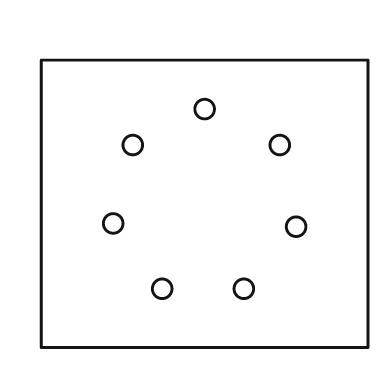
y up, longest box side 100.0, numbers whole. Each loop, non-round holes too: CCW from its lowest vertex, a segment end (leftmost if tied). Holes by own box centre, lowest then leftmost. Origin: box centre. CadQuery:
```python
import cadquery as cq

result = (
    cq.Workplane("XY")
    .moveTo(-50.0, -44.0)
    .lineTo(50.0, -44.0)
    .lineTo(50.0, 44.0)
    .lineTo(-50.0, 44.0)
    .close()
    .moveTo(-13.0, -26.0)
    .circle(3.0)
    .moveTo(12.0, -26.0)
    .circle(3.0)
    .moveTo(28.0, -7.0)
    .circle(3.0)
    .moveTo(-28.0, -6.0)
    .circle(3.0)
    .moveTo(-22.0, 18.0)
    .circle(3.0)
    .moveTo(23.0, 18.0)
    .circle(3.0)
    .moveTo(0.0, 29.0)
    .circle(3.0)
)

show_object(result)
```